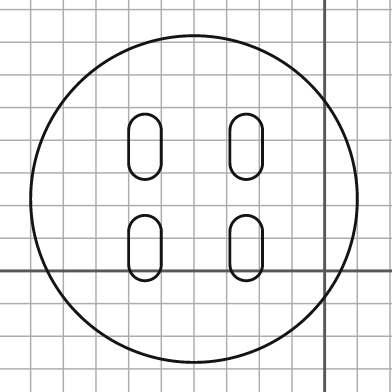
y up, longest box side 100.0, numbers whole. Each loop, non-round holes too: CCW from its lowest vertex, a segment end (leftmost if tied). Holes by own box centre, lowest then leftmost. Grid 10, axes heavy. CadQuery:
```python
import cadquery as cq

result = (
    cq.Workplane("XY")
    .moveTo(-40.0, 22.0)
    .circle(50.0)
    .moveTo(-60.0, 2.0)
    .threePointArc((-55.0, -3.0), (-50.0, 2.0))
    .lineTo(-50.0, 12.0)
    .threePointArc((-55.0, 17.0), (-60.0, 12.0))
    .close()
    .moveTo(-29.0, 2.0)
    .threePointArc((-24.0, -3.0), (-19.0, 2.0))
    .lineTo(-19.0, 12.0)
    .threePointArc((-24.0, 17.0), (-29.0, 12.0))
    .close()
    .moveTo(-60.0, 33.0)
    .threePointArc((-55.0, 28.0), (-50.0, 33.0))
    .lineTo(-50.0, 43.0)
    .threePointArc((-55.0, 48.0), (-60.0, 43.0))
    .close()
    .moveTo(-29.0, 33.0)
    .threePointArc((-24.0, 28.0), (-19.0, 33.0))
    .lineTo(-19.0, 43.0)
    .threePointArc((-24.0, 48.0), (-29.0, 43.0))
    .close()
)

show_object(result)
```